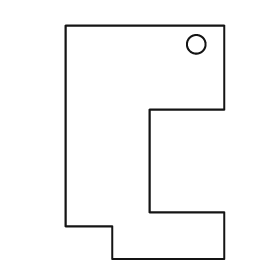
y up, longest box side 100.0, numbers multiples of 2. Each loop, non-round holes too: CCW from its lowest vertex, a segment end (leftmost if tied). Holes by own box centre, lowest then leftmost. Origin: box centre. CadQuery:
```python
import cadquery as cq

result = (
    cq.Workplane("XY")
    .moveTo(-14.0, -50.0)
    .lineTo(34.0, -50.0)
    .lineTo(34.0, -30.0)
    .lineTo(2.0, -30.0)
    .lineTo(2.0, 14.0)
    .lineTo(34.0, 14.0)
    .lineTo(34.0, 50.0)
    .lineTo(-34.0, 50.0)
    .lineTo(-34.0, -36.0)
    .lineTo(-14.0, -36.0)
    .close()
    .moveTo(22.0, 42.0)
    .circle(4.0)
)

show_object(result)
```